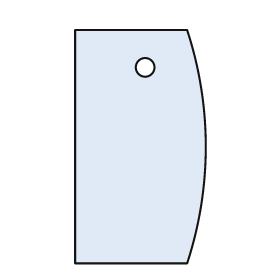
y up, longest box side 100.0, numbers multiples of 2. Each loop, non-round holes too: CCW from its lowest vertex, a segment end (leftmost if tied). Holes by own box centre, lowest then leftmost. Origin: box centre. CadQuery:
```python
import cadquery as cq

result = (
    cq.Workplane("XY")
    .moveTo(-28.0, -50.0)
    .lineTo(20.0, -50.0)
    .threePointArc((28.0, 0.0), (20.0, 50.0))
    .lineTo(-28.0, 50.0)
    .close()
    .moveTo(2.0, 34.0)
    .circle(4.0)
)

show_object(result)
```